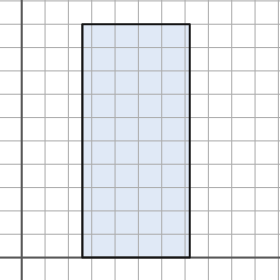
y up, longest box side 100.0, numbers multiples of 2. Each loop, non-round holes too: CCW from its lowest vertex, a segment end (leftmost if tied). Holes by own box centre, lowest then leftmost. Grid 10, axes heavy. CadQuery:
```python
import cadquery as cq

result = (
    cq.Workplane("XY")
    .moveTo(26.0, 0.0)
    .lineTo(72.0, 0.0)
    .lineTo(72.0, 100.0)
    .lineTo(26.0, 100.0)
    .close()
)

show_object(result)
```